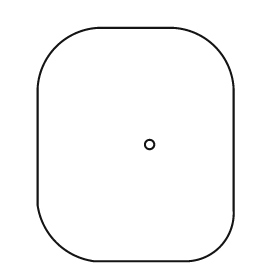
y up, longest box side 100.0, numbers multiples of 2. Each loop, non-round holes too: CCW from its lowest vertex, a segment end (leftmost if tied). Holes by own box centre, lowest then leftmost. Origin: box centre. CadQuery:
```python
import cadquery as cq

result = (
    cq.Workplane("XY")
    .moveTo(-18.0, -50.0)
    .lineTo(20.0, -50.0)
    .threePointArc((36.0, -44.0), (42.0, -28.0))
    .lineTo(42.0, 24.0)
    .threePointArc((34.0, 42.0), (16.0, 50.0))
    .lineTo(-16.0, 50.0)
    .threePointArc((-34.0, 42.0), (-42.0, 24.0))
    .lineTo(-42.0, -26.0)
    .threePointArc((-34.0, -42.0), (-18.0, -50.0))
    .close()
    .moveTo(6.0, 0.0)
    .circle(2.0)
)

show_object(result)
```